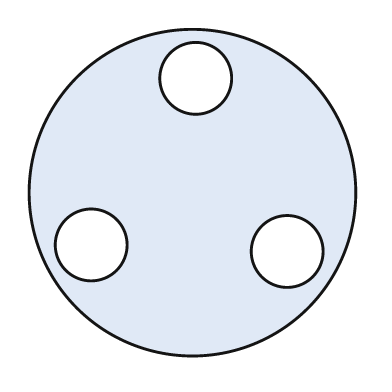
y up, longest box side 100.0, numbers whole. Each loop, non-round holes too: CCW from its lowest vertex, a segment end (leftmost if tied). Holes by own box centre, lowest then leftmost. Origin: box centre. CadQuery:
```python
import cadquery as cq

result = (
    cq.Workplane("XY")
    .moveTo(0.0, 0.0)
    .circle(50.0)
    .moveTo(29.0, -18.0)
    .circle(11.0)
    .moveTo(-31.0, -16.0)
    .circle(11.0)
    .moveTo(1.0, 35.0)
    .circle(11.0)
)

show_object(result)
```